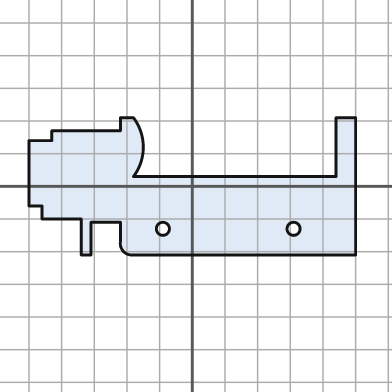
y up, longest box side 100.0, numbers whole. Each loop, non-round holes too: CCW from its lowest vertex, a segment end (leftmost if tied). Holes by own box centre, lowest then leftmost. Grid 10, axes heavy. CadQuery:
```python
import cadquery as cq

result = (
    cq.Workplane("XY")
    .moveTo(-34.0, -21.0)
    .lineTo(-31.0, -21.0)
    .lineTo(-31.0, -11.0)
    .lineTo(-22.0, -11.0)
    .lineTo(-22.0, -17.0)
    .threePointArc((-21.0, -20.0), (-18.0, -21.0))
    .lineTo(50.0, -21.0)
    .lineTo(50.0, 21.0)
    .lineTo(44.0, 21.0)
    .lineTo(44.0, 3.0)
    .lineTo(-18.0, 3.0)
    .threePointArc((-15.0, 12.0), (-18.0, 21.0))
    .lineTo(-22.0, 21.0)
    .lineTo(-22.0, 17.0)
    .lineTo(-43.0, 17.0)
    .lineTo(-43.0, 14.0)
    .lineTo(-50.0, 14.0)
    .lineTo(-50.0, -6.0)
    .lineTo(-46.0, -6.0)
    .lineTo(-46.0, -10.0)
    .lineTo(-34.0, -10.0)
    .close()
    .moveTo(-9.0, -13.0)
    .circle(2.0)
    .moveTo(31.0, -13.0)
    .circle(2.0)
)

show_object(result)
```